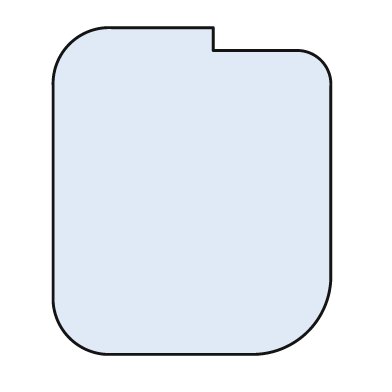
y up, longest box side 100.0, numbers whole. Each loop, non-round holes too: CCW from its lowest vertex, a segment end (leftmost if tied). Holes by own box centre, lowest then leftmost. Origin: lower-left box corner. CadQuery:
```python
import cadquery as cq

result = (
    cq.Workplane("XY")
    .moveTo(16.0, 0.0)
    .lineTo(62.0, 0.0)
    .threePointArc((78.0, 7.0), (85.0, 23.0))
    .lineTo(85.0, 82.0)
    .threePointArc((82.0, 90.0), (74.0, 93.0))
    .lineTo(49.0, 93.0)
    .lineTo(49.0, 100.0)
    .lineTo(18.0, 100.0)
    .threePointArc((5.0, 95.0), (0.0, 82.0))
    .lineTo(0.0, 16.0)
    .threePointArc((5.0, 5.0), (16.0, 0.0))
    .close()
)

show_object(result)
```